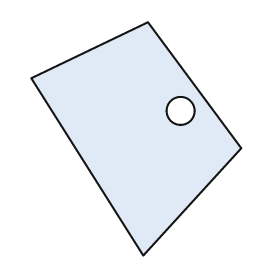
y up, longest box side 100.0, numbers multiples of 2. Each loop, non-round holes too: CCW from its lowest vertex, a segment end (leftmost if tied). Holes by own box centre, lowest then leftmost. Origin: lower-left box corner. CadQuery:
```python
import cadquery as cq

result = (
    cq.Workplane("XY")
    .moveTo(48.0, 0.0)
    .lineTo(90.0, 46.0)
    .lineTo(50.0, 100.0)
    .lineTo(0.0, 76.0)
    .close()
    .moveTo(64.0, 62.0)
    .circle(6.0)
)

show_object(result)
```